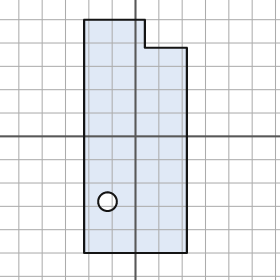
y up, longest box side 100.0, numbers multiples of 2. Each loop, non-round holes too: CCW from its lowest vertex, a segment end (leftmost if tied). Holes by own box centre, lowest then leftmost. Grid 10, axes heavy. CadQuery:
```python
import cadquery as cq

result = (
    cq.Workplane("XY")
    .moveTo(-22.0, -50.0)
    .lineTo(22.0, -50.0)
    .lineTo(22.0, 38.0)
    .lineTo(4.0, 38.0)
    .lineTo(4.0, 50.0)
    .lineTo(-22.0, 50.0)
    .close()
    .moveTo(-12.0, -28.0)
    .circle(4.0)
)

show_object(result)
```